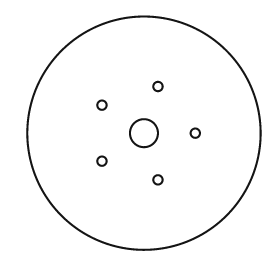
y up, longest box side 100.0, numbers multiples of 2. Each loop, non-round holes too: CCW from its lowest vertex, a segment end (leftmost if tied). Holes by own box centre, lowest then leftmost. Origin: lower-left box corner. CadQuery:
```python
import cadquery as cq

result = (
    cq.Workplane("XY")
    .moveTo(50.0, 50.0)
    .circle(50.0)
    .moveTo(56.0, 30.0)
    .circle(2.0)
    .moveTo(32.0, 38.0)
    .circle(2.0)
    .moveTo(50.0, 50.0)
    .circle(6.0)
    .moveTo(72.0, 50.0)
    .circle(2.0)
    .moveTo(32.0, 62.0)
    .circle(2.0)
    .moveTo(56.0, 70.0)
    .circle(2.0)
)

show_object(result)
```